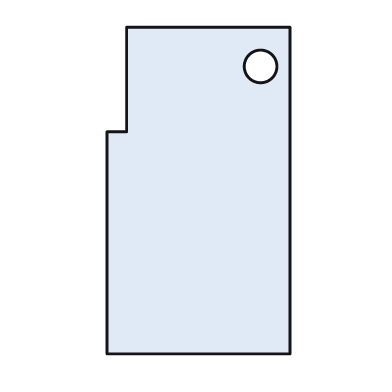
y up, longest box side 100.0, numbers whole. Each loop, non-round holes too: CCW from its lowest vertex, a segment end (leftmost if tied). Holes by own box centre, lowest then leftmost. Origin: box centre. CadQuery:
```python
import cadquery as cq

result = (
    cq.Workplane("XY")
    .moveTo(-28.0, -50.0)
    .lineTo(28.0, -50.0)
    .lineTo(28.0, 50.0)
    .lineTo(-22.0, 50.0)
    .lineTo(-22.0, 18.0)
    .lineTo(-28.0, 18.0)
    .close()
    .moveTo(19.0, 38.0)
    .circle(5.0)
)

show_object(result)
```